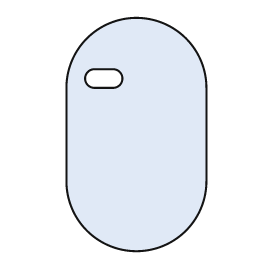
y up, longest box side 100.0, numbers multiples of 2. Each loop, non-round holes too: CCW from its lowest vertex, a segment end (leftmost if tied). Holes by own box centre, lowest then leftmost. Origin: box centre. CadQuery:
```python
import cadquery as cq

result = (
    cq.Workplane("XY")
    .moveTo(-30.0, -20.0)
    .threePointArc((0.0, -50.0), (30.0, -20.0))
    .lineTo(30.0, 20.0)
    .threePointArc((0.0, 50.0), (-30.0, 20.0))
    .close()
    .moveTo(-18.0, 20.0)
    .lineTo(-10.0, 20.0)
    .threePointArc((-6.0, 24.0), (-10.0, 28.0))
    .lineTo(-18.0, 28.0)
    .threePointArc((-22.0, 24.0), (-18.0, 20.0))
    .close()
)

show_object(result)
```